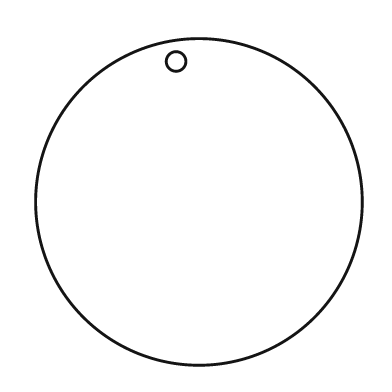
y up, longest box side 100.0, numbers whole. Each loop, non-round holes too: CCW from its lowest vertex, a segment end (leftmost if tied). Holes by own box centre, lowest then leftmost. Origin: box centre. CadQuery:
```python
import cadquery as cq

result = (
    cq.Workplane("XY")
    .moveTo(0.0, 0.0)
    .circle(50.0)
    .moveTo(-7.0, 43.0)
    .circle(3.0)
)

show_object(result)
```